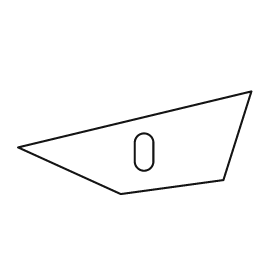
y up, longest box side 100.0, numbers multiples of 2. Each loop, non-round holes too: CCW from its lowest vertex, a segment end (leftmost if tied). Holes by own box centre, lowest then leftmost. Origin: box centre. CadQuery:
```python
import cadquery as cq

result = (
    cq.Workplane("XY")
    .moveTo(-6.0, -22.0)
    .lineTo(38.0, -16.0)
    .lineTo(50.0, 22.0)
    .lineTo(-50.0, -2.0)
    .close()
    .moveTo(0.0, -8.0)
    .threePointArc((4.0, -12.0), (8.0, -8.0))
    .lineTo(8.0, 0.0)
    .threePointArc((4.0, 4.0), (0.0, 0.0))
    .close()
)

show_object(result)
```